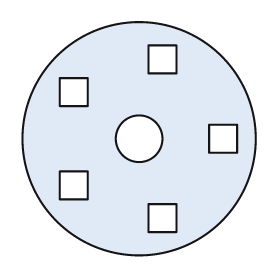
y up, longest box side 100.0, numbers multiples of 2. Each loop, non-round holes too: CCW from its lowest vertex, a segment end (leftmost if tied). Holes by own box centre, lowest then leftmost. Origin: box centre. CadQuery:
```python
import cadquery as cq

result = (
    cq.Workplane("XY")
    .moveTo(0.0, 0.0)
    .circle(50.0)
    .moveTo(4.0, -40.0)
    .lineTo(16.0, -40.0)
    .lineTo(16.0, -28.0)
    .lineTo(4.0, -28.0)
    .close()
    .moveTo(-34.0, -26.0)
    .lineTo(-22.0, -26.0)
    .lineTo(-22.0, -14.0)
    .lineTo(-34.0, -14.0)
    .close()
    .moveTo(0.0, 0.0)
    .circle(10.0)
    .moveTo(30.0, -6.0)
    .lineTo(42.0, -6.0)
    .lineTo(42.0, 6.0)
    .lineTo(30.0, 6.0)
    .close()
    .moveTo(-34.0, 14.0)
    .lineTo(-22.0, 14.0)
    .lineTo(-22.0, 26.0)
    .lineTo(-34.0, 26.0)
    .close()
    .moveTo(4.0, 28.0)
    .lineTo(16.0, 28.0)
    .lineTo(16.0, 40.0)
    .lineTo(4.0, 40.0)
    .close()
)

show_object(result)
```